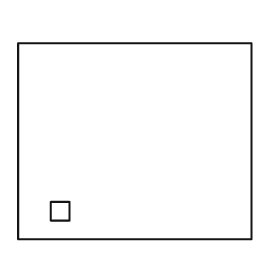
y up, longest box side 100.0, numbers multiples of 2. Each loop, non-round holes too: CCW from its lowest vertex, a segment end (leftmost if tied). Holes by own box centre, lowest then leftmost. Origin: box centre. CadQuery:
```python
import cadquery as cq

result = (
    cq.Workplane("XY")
    .moveTo(-50.0, -42.0)
    .lineTo(50.0, -42.0)
    .lineTo(50.0, 42.0)
    .lineTo(-50.0, 42.0)
    .close()
    .moveTo(-36.0, -34.0)
    .lineTo(-28.0, -34.0)
    .lineTo(-28.0, -26.0)
    .lineTo(-36.0, -26.0)
    .close()
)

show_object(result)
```